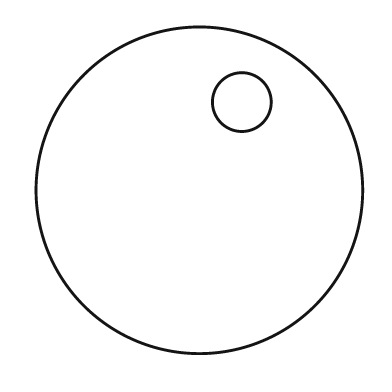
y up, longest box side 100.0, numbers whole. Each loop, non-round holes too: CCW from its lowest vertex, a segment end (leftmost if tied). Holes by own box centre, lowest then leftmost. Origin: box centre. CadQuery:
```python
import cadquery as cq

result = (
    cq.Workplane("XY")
    .moveTo(0.0, 0.0)
    .circle(50.0)
    .moveTo(13.0, 27.0)
    .circle(9.0)
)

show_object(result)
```